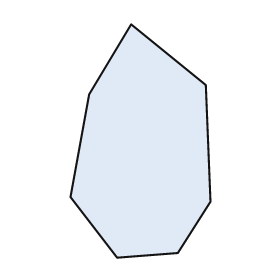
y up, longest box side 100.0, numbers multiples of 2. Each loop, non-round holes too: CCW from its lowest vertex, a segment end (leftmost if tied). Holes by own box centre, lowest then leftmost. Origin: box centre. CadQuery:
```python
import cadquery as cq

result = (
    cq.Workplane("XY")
    .moveTo(-10.0, -50.0)
    .lineTo(16.0, -48.0)
    .lineTo(30.0, -26.0)
    .lineTo(28.0, 24.0)
    .lineTo(-4.0, 50.0)
    .lineTo(-22.0, 20.0)
    .lineTo(-30.0, -24.0)
    .close()
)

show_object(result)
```